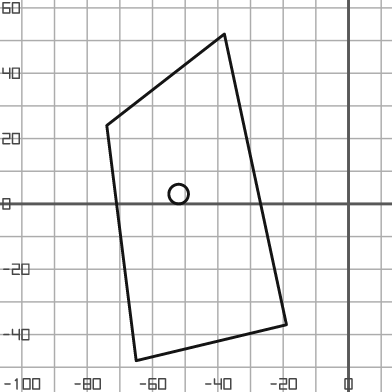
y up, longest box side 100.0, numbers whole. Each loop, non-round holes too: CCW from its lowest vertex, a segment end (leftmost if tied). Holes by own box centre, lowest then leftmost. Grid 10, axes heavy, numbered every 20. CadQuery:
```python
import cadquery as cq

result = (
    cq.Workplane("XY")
    .moveTo(-65.0, -48.0)
    .lineTo(-19.0, -37.0)
    .lineTo(-38.0, 52.0)
    .lineTo(-74.0, 24.0)
    .close()
    .moveTo(-52.0, 3.0)
    .circle(3.0)
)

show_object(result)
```